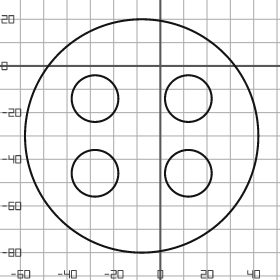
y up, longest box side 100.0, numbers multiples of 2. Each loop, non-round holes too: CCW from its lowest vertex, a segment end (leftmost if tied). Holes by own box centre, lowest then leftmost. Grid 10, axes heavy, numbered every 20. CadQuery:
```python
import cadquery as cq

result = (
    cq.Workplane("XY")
    .moveTo(-8.0, -30.0)
    .circle(50.0)
    .moveTo(-28.0, -46.0)
    .circle(10.0)
    .moveTo(12.0, -46.0)
    .circle(10.0)
    .moveTo(-28.0, -14.0)
    .circle(10.0)
    .moveTo(12.0, -14.0)
    .circle(10.0)
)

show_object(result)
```